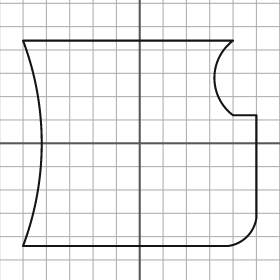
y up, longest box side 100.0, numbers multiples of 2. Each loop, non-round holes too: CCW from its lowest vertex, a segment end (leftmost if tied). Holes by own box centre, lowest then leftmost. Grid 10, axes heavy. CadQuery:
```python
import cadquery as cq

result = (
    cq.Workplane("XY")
    .moveTo(-50.0, -44.0)
    .lineTo(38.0, -44.0)
    .threePointArc((46.0, -40.0), (50.0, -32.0))
    .lineTo(50.0, 12.0)
    .lineTo(40.0, 12.0)
    .threePointArc((32.0, 28.0), (40.0, 44.0))
    .lineTo(-50.0, 44.0)
    .threePointArc((-42.0, 0.0), (-50.0, -44.0))
    .close()
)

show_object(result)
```